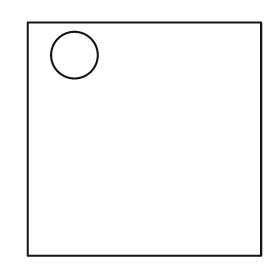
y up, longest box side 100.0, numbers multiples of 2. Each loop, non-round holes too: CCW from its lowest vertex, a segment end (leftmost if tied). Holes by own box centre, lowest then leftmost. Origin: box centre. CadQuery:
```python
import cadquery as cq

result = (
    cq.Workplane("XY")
    .moveTo(-50.0, -50.0)
    .lineTo(50.0, -50.0)
    .lineTo(50.0, 50.0)
    .lineTo(-50.0, 50.0)
    .close()
    .moveTo(-30.0, 36.0)
    .circle(10.0)
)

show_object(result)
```